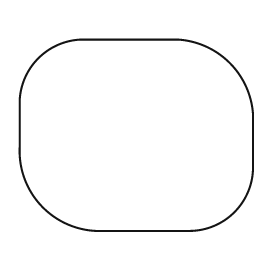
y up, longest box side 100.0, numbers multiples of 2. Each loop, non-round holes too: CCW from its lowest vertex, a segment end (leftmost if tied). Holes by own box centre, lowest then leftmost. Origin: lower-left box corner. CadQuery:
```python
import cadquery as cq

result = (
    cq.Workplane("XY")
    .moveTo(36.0, 0.0)
    .lineTo(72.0, 0.0)
    .threePointArc((92.0, 8.0), (100.0, 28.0))
    .lineTo(100.0, 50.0)
    .threePointArc((90.0, 72.0), (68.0, 82.0))
    .lineTo(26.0, 82.0)
    .threePointArc((8.0, 74.0), (0.0, 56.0))
    .lineTo(0.0, 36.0)
    .threePointArc((10.0, 10.0), (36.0, 0.0))
    .close()
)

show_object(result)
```